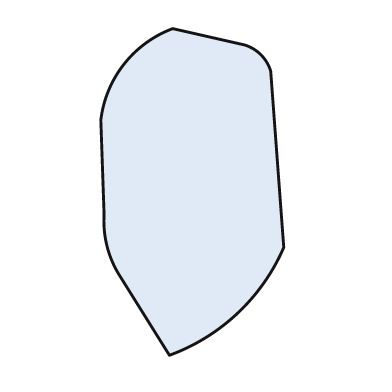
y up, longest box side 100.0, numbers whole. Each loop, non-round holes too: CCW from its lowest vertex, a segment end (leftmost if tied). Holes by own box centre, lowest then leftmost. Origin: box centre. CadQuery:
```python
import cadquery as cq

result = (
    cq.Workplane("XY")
    .moveTo(-7.0, -50.0)
    .threePointArc((14.0, -37.0), (28.0, -17.0))
    .lineTo(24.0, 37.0)
    .threePointArc((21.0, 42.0), (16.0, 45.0))
    .lineTo(-6.0, 50.0)
    .threePointArc((-21.0, 39.0), (-28.0, 22.0))
    .lineTo(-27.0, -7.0)
    .threePointArc((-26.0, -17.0), (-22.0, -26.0))
    .close()
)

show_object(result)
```